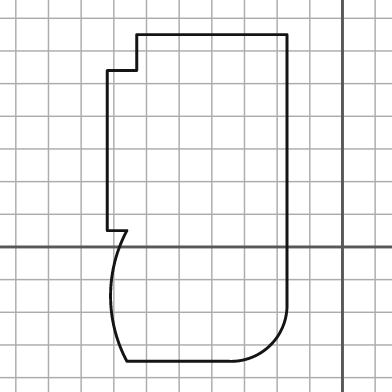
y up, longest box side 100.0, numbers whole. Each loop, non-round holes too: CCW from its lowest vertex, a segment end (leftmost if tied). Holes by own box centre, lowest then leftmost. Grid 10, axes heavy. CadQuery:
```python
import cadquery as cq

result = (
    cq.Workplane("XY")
    .moveTo(-66.0, -35.0)
    .lineTo(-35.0, -35.0)
    .threePointArc((-22.0, -30.0), (-17.0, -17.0))
    .lineTo(-17.0, 65.0)
    .lineTo(-63.0, 65.0)
    .lineTo(-63.0, 54.0)
    .lineTo(-72.0, 54.0)
    .lineTo(-72.0, 5.0)
    .lineTo(-66.0, 5.0)
    .threePointArc((-71.0, -15.0), (-66.0, -35.0))
    .close()
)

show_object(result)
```